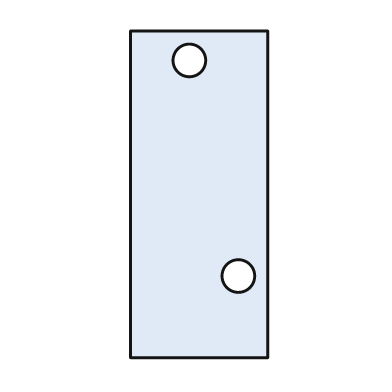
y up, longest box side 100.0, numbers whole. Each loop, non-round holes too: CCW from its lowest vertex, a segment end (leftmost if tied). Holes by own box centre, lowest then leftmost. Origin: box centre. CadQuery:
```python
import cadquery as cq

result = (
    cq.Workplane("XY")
    .moveTo(-21.0, -50.0)
    .lineTo(21.0, -50.0)
    .lineTo(21.0, 50.0)
    .lineTo(-21.0, 50.0)
    .close()
    .moveTo(12.0, -25.0)
    .circle(5.0)
    .moveTo(-3.0, 41.0)
    .circle(5.0)
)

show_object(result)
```